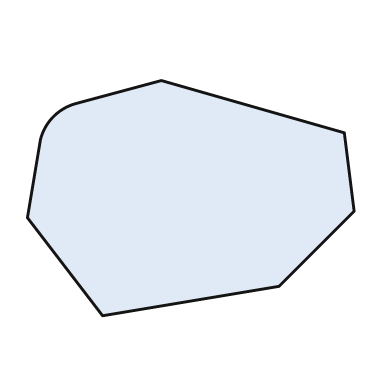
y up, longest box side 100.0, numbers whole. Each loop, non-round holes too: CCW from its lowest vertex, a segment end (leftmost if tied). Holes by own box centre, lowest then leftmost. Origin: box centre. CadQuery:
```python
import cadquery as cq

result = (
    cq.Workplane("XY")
    .moveTo(-27.0, -36.0)
    .lineTo(27.0, -27.0)
    .lineTo(50.0, -4.0)
    .lineTo(47.0, 20.0)
    .lineTo(-9.0, 36.0)
    .lineTo(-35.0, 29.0)
    .threePointArc((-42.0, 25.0), (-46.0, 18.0))
    .lineTo(-50.0, -6.0)
    .close()
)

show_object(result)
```